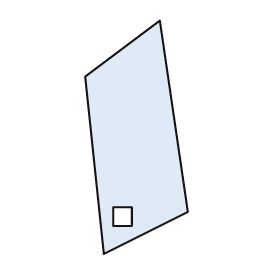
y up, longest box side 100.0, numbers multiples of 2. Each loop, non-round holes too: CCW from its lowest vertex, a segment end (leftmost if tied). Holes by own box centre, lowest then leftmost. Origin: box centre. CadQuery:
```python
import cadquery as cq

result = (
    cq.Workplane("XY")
    .moveTo(-14.0, -50.0)
    .lineTo(22.0, -32.0)
    .lineTo(10.0, 50.0)
    .lineTo(-22.0, 26.0)
    .close()
    .moveTo(-10.0, -38.0)
    .lineTo(-2.0, -38.0)
    .lineTo(-2.0, -30.0)
    .lineTo(-10.0, -30.0)
    .close()
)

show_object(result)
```